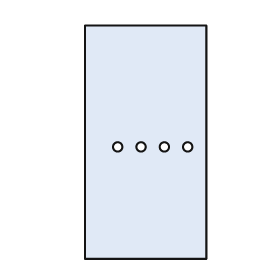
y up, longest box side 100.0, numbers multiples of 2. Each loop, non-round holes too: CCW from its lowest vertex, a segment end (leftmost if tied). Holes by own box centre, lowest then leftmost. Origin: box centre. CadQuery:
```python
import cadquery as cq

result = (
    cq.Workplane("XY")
    .moveTo(-26.0, -50.0)
    .lineTo(26.0, -50.0)
    .lineTo(26.0, 50.0)
    .lineTo(-26.0, 50.0)
    .close()
    .moveTo(-12.0, -2.0)
    .circle(2.0)
    .moveTo(-2.0, -2.0)
    .circle(2.0)
    .moveTo(8.0, -2.0)
    .circle(2.0)
    .moveTo(18.0, -2.0)
    .circle(2.0)
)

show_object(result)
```